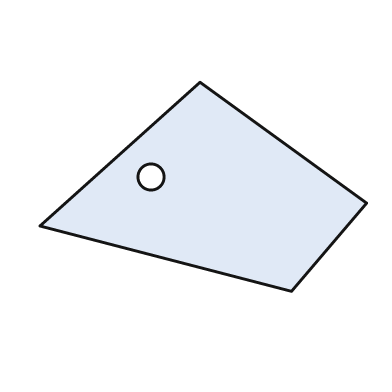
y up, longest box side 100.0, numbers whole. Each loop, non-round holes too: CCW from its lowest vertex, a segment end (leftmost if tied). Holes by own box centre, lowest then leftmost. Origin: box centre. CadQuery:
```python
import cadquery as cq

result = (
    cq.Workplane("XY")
    .moveTo(27.0, -32.0)
    .lineTo(50.0, -5.0)
    .lineTo(-1.0, 32.0)
    .lineTo(-50.0, -12.0)
    .close()
    .moveTo(-16.0, 3.0)
    .circle(4.0)
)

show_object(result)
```